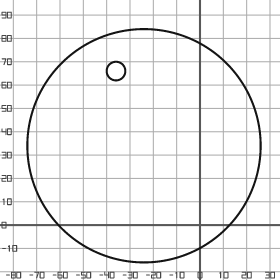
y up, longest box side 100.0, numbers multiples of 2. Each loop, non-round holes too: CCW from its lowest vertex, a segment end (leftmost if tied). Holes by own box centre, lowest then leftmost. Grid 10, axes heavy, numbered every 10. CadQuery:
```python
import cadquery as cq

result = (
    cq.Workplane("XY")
    .moveTo(-24.0, 34.0)
    .circle(50.0)
    .moveTo(-36.0, 66.0)
    .circle(4.0)
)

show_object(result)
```